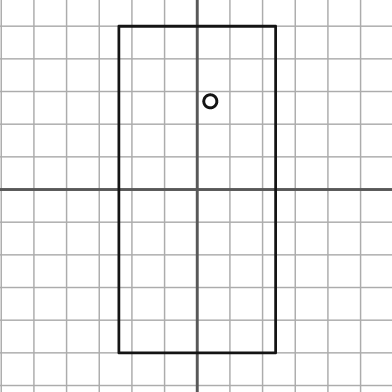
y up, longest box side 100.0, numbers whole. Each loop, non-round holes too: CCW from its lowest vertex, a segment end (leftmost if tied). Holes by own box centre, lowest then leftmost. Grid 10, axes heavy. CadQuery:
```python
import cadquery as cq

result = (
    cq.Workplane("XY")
    .moveTo(-24.0, -50.0)
    .lineTo(24.0, -50.0)
    .lineTo(24.0, 50.0)
    .lineTo(-24.0, 50.0)
    .close()
    .moveTo(4.0, 27.0)
    .circle(2.0)
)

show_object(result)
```